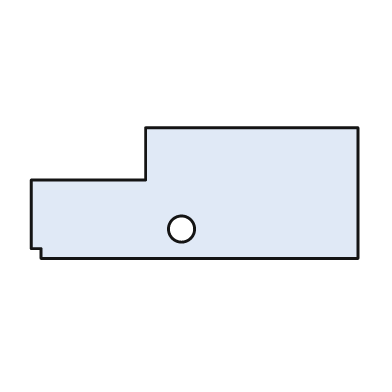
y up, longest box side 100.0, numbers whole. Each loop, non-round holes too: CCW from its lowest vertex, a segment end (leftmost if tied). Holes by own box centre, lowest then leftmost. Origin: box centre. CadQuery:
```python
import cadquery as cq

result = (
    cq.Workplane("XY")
    .moveTo(-47.0, -20.0)
    .lineTo(50.0, -20.0)
    .lineTo(50.0, 20.0)
    .lineTo(-15.0, 20.0)
    .lineTo(-15.0, 4.0)
    .lineTo(-50.0, 4.0)
    .lineTo(-50.0, -17.0)
    .lineTo(-47.0, -17.0)
    .close()
    .moveTo(-4.0, -11.0)
    .circle(4.0)
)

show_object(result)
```